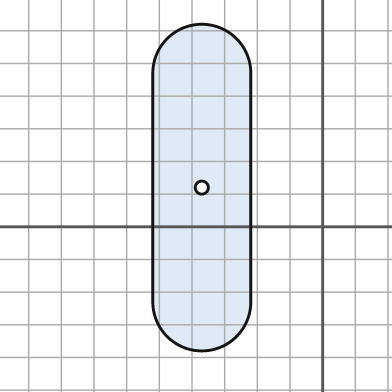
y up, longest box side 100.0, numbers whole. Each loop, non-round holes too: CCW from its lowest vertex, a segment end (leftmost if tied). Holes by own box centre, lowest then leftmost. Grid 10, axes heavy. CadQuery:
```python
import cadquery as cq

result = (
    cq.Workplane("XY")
    .moveTo(-52.0, -23.0)
    .threePointArc((-37.0, -38.0), (-22.0, -23.0))
    .lineTo(-22.0, 47.0)
    .threePointArc((-37.0, 62.0), (-52.0, 47.0))
    .close()
    .moveTo(-37.0, 12.0)
    .circle(2.0)
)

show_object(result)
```